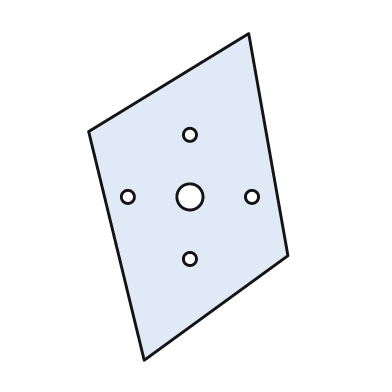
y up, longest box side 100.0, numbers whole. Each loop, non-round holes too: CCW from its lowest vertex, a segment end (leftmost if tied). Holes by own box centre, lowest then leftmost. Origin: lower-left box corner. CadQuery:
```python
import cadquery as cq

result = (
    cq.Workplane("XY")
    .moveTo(17.0, 0.0)
    .lineTo(61.0, 32.0)
    .lineTo(49.0, 100.0)
    .lineTo(0.0, 70.0)
    .close()
    .moveTo(31.0, 31.0)
    .circle(2.0)
    .moveTo(12.0, 50.0)
    .circle(2.0)
    .moveTo(31.0, 50.0)
    .circle(4.0)
    .moveTo(50.0, 50.0)
    .circle(2.0)
    .moveTo(31.0, 69.0)
    .circle(2.0)
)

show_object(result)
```